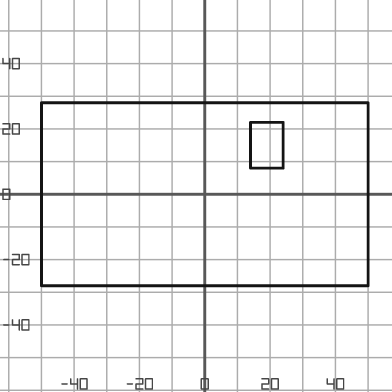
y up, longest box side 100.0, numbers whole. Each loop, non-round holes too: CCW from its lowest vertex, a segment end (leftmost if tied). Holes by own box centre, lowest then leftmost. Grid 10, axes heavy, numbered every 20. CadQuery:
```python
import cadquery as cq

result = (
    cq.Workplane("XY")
    .moveTo(-50.0, -28.0)
    .lineTo(50.0, -28.0)
    .lineTo(50.0, 28.0)
    .lineTo(-50.0, 28.0)
    .close()
    .moveTo(14.0, 8.0)
    .lineTo(24.0, 8.0)
    .lineTo(24.0, 22.0)
    .lineTo(14.0, 22.0)
    .close()
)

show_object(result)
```